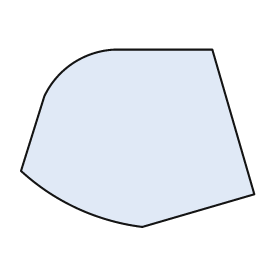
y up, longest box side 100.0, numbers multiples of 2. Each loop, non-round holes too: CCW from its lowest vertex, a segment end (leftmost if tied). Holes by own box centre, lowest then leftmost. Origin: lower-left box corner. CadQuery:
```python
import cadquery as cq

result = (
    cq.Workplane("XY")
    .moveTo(52.0, 0.0)
    .lineTo(100.0, 14.0)
    .lineTo(82.0, 76.0)
    .lineTo(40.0, 76.0)
    .threePointArc((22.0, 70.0), (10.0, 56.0))
    .lineTo(0.0, 24.0)
    .threePointArc((24.0, 8.0), (52.0, 0.0))
    .close()
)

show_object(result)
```